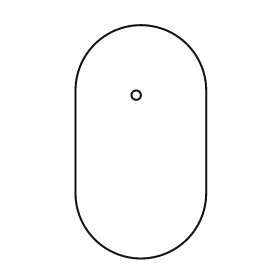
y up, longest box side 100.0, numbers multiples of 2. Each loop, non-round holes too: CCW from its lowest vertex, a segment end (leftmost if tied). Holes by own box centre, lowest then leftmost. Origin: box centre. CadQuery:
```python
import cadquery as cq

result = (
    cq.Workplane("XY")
    .moveTo(-28.0, -22.0)
    .threePointArc((0.0, -50.0), (28.0, -22.0))
    .lineTo(28.0, 22.0)
    .threePointArc((0.0, 50.0), (-28.0, 22.0))
    .close()
    .moveTo(-2.0, 20.0)
    .circle(2.0)
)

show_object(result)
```